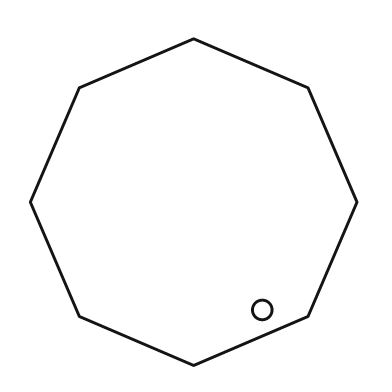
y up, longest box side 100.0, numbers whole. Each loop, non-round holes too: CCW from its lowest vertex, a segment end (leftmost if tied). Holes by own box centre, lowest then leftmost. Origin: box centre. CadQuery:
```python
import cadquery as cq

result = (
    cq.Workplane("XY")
    .moveTo(0.0, -50.0)
    .lineTo(35.0, -35.0)
    .lineTo(50.0, 0.0)
    .lineTo(35.0, 35.0)
    .lineTo(0.0, 50.0)
    .lineTo(-35.0, 35.0)
    .lineTo(-50.0, 0.0)
    .lineTo(-35.0, -35.0)
    .close()
    .moveTo(21.0, -33.0)
    .circle(3.0)
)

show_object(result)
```